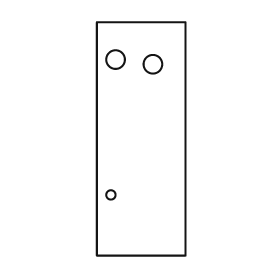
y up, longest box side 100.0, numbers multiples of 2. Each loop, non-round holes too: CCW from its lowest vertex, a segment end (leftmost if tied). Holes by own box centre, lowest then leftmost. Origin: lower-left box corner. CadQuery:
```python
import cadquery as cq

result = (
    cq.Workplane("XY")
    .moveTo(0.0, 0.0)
    .lineTo(38.0, 0.0)
    .lineTo(38.0, 100.0)
    .lineTo(0.0, 100.0)
    .close()
    .moveTo(6.0, 26.0)
    .circle(2.0)
    .moveTo(24.0, 82.0)
    .circle(4.0)
    .moveTo(8.0, 84.0)
    .circle(4.0)
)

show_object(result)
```